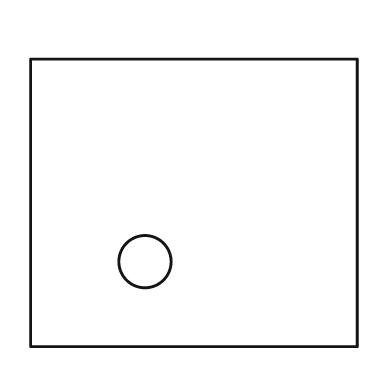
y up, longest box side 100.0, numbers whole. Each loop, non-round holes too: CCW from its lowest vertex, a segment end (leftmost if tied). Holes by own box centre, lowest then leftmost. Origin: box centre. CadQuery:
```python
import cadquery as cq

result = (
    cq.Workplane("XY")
    .moveTo(-50.0, -44.0)
    .lineTo(50.0, -44.0)
    .lineTo(50.0, 44.0)
    .lineTo(-50.0, 44.0)
    .close()
    .moveTo(-15.0, -18.0)
    .circle(8.0)
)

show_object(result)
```